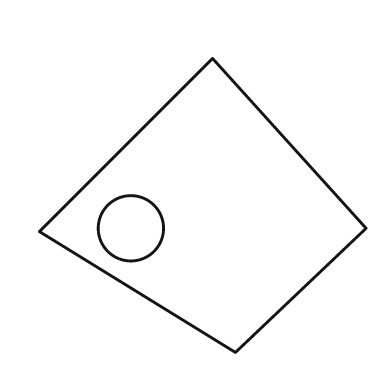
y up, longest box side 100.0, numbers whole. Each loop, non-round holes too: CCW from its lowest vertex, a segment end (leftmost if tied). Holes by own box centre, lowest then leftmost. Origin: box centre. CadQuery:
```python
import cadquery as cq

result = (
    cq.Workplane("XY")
    .moveTo(10.0, -45.0)
    .lineTo(50.0, -7.0)
    .lineTo(3.0, 45.0)
    .lineTo(-50.0, -8.0)
    .close()
    .moveTo(-22.0, -7.0)
    .circle(10.0)
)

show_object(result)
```